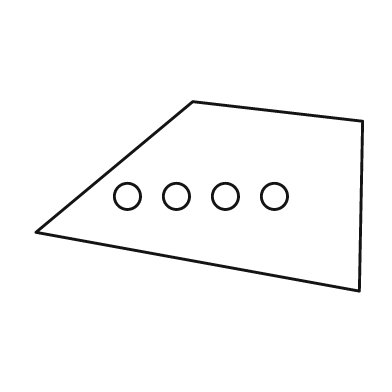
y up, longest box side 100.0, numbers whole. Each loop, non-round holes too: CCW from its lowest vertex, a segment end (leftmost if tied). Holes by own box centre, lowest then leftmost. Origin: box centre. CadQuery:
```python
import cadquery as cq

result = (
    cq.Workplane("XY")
    .moveTo(49.0, -29.0)
    .lineTo(50.0, 23.0)
    .lineTo(-2.0, 29.0)
    .lineTo(-50.0, -11.0)
    .close()
    .moveTo(-22.0, 0.0)
    .circle(4.0)
    .moveTo(-7.0, 0.0)
    .circle(4.0)
    .moveTo(8.0, 0.0)
    .circle(4.0)
    .moveTo(23.0, 0.0)
    .circle(4.0)
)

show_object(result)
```